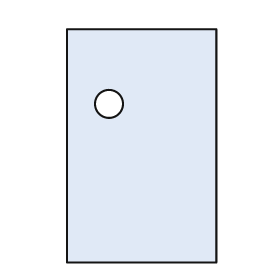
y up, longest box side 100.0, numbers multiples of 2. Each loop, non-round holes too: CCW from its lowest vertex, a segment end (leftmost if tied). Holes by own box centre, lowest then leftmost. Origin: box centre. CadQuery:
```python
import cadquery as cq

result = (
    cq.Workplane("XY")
    .moveTo(-32.0, -50.0)
    .lineTo(32.0, -50.0)
    .lineTo(32.0, 50.0)
    .lineTo(-32.0, 50.0)
    .close()
    .moveTo(-14.0, 18.0)
    .circle(6.0)
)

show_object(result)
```